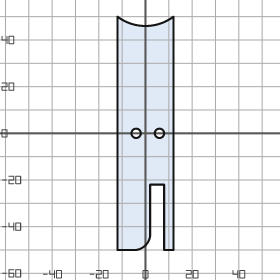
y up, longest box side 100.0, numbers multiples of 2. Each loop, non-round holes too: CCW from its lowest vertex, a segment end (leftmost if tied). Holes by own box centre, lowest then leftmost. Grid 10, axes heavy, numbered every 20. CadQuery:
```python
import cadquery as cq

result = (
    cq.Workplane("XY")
    .moveTo(-12.0, -50.0)
    .lineTo(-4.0, -50.0)
    .threePointArc((0.0, -48.0), (2.0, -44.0))
    .lineTo(2.0, -22.0)
    .lineTo(8.0, -22.0)
    .lineTo(8.0, -50.0)
    .lineTo(12.0, -50.0)
    .lineTo(12.0, 50.0)
    .threePointArc((0.0, 46.0), (-12.0, 50.0))
    .close()
    .moveTo(-4.0, 0.0)
    .circle(2.0)
    .moveTo(6.0, 0.0)
    .circle(2.0)
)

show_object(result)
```